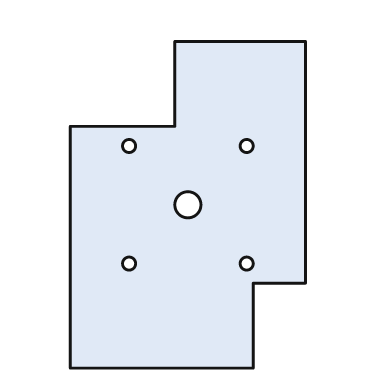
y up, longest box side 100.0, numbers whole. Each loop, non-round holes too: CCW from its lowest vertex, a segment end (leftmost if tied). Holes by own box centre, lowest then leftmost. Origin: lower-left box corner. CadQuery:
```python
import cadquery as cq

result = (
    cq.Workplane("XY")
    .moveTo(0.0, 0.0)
    .lineTo(56.0, 0.0)
    .lineTo(56.0, 26.0)
    .lineTo(72.0, 26.0)
    .lineTo(72.0, 100.0)
    .lineTo(32.0, 100.0)
    .lineTo(32.0, 74.0)
    .lineTo(0.0, 74.0)
    .close()
    .moveTo(18.0, 32.0)
    .circle(2.0)
    .moveTo(54.0, 32.0)
    .circle(2.0)
    .moveTo(36.0, 50.0)
    .circle(4.0)
    .moveTo(18.0, 68.0)
    .circle(2.0)
    .moveTo(54.0, 68.0)
    .circle(2.0)
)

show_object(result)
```